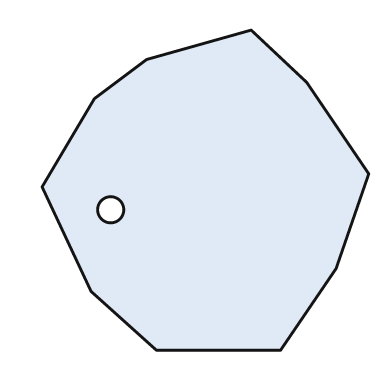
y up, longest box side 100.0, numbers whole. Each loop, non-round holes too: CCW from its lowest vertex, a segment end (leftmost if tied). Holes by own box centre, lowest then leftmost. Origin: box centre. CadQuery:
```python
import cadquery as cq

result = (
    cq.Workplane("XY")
    .moveTo(-15.0, -49.0)
    .lineTo(23.0, -49.0)
    .lineTo(40.0, -24.0)
    .lineTo(50.0, 5.0)
    .lineTo(31.0, 33.0)
    .lineTo(14.0, 49.0)
    .lineTo(-18.0, 40.0)
    .lineTo(-34.0, 28.0)
    .lineTo(-50.0, 1.0)
    .lineTo(-35.0, -31.0)
    .close()
    .moveTo(-29.0, -6.0)
    .circle(4.0)
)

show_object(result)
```